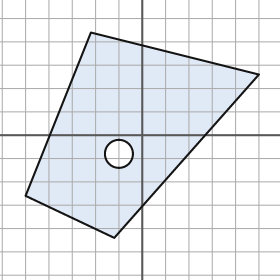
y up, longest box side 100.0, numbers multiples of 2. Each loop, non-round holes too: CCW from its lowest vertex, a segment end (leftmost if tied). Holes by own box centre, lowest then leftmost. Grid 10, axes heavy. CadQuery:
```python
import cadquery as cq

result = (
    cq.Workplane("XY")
    .moveTo(-12.0, -44.0)
    .lineTo(50.0, 26.0)
    .lineTo(-22.0, 44.0)
    .lineTo(-50.0, -26.0)
    .close()
    .moveTo(-10.0, -8.0)
    .circle(6.0)
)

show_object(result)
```